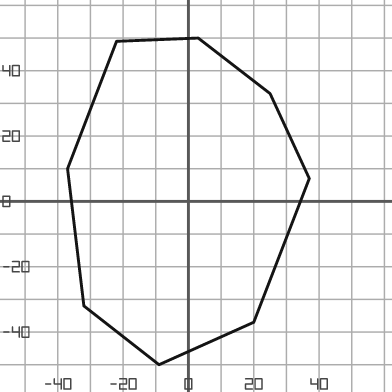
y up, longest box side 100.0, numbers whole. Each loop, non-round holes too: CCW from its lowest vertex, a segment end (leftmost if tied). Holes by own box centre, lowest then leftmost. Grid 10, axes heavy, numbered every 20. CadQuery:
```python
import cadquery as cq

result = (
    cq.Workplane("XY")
    .moveTo(-9.0, -50.0)
    .lineTo(20.0, -37.0)
    .lineTo(37.0, 7.0)
    .lineTo(25.0, 33.0)
    .lineTo(3.0, 50.0)
    .lineTo(-22.0, 49.0)
    .lineTo(-37.0, 10.0)
    .lineTo(-32.0, -32.0)
    .close()
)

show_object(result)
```